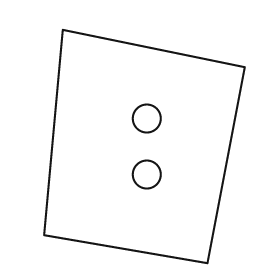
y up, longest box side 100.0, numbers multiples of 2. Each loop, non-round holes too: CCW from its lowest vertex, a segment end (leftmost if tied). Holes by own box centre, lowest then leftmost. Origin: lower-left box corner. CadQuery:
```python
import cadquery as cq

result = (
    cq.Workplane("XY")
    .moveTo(70.0, 0.0)
    .lineTo(86.0, 84.0)
    .lineTo(8.0, 100.0)
    .lineTo(0.0, 12.0)
    .close()
    .moveTo(44.0, 38.0)
    .circle(6.0)
    .moveTo(44.0, 62.0)
    .circle(6.0)
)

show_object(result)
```